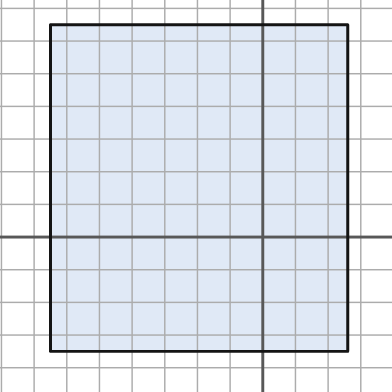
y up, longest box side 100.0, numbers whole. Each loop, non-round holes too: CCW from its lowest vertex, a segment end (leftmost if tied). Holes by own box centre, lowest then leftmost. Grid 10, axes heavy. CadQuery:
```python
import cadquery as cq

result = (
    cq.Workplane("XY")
    .moveTo(-65.0, -35.0)
    .lineTo(26.0, -35.0)
    .lineTo(26.0, 65.0)
    .lineTo(-65.0, 65.0)
    .close()
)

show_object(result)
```